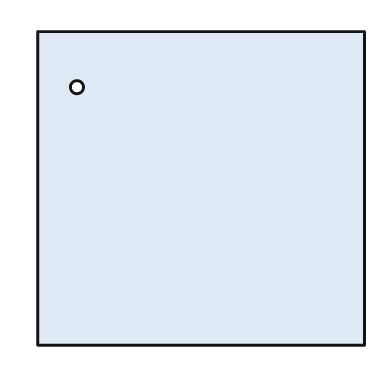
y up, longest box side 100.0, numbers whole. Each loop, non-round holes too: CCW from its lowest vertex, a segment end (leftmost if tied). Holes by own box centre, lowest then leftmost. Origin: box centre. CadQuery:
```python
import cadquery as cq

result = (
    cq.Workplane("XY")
    .moveTo(-50.0, -48.0)
    .lineTo(50.0, -48.0)
    .lineTo(50.0, 48.0)
    .lineTo(-50.0, 48.0)
    .close()
    .moveTo(-38.0, 31.0)
    .circle(2.0)
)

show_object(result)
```